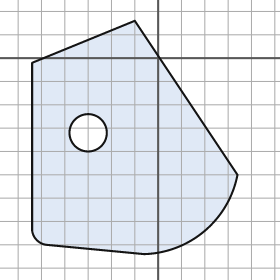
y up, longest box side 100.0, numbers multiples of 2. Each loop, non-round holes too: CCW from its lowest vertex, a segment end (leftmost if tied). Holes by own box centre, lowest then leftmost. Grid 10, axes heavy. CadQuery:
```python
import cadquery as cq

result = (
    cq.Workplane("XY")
    .moveTo(-6.0, -84.0)
    .threePointArc((20.0, -74.0), (34.0, -50.0))
    .lineTo(-10.0, 16.0)
    .lineTo(-54.0, -2.0)
    .lineTo(-54.0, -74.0)
    .threePointArc((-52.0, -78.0), (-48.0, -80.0))
    .close()
    .moveTo(-30.0, -32.0)
    .circle(8.0)
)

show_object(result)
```